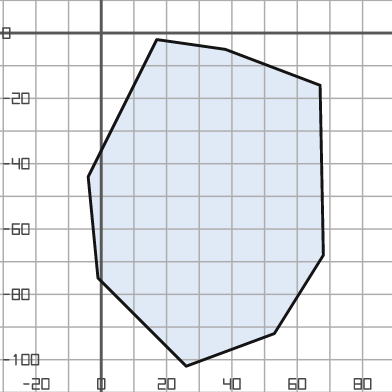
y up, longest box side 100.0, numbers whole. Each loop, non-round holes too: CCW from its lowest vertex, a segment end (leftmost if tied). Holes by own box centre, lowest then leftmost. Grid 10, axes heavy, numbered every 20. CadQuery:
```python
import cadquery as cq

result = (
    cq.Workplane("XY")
    .moveTo(26.0, -102.0)
    .lineTo(53.0, -92.0)
    .lineTo(68.0, -68.0)
    .lineTo(67.0, -16.0)
    .lineTo(38.0, -5.0)
    .lineTo(17.0, -2.0)
    .lineTo(-4.0, -44.0)
    .lineTo(-1.0, -75.0)
    .close()
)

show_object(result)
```